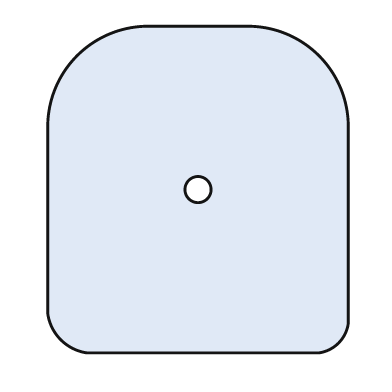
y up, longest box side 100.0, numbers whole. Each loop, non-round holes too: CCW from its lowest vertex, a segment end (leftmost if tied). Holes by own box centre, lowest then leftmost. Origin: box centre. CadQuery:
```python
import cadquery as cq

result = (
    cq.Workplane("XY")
    .moveTo(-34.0, -50.0)
    .lineTo(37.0, -50.0)
    .threePointArc((43.0, -47.0), (46.0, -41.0))
    .lineTo(46.0, 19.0)
    .threePointArc((37.0, 41.0), (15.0, 50.0))
    .lineTo(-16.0, 50.0)
    .threePointArc((-37.0, 41.0), (-46.0, 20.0))
    .lineTo(-46.0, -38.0)
    .threePointArc((-42.0, -46.0), (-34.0, -50.0))
    .close()
    .moveTo(0.0, 0.0)
    .circle(4.0)
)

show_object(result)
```